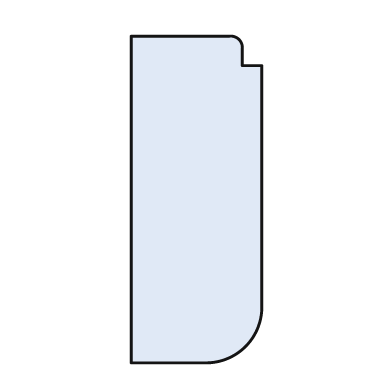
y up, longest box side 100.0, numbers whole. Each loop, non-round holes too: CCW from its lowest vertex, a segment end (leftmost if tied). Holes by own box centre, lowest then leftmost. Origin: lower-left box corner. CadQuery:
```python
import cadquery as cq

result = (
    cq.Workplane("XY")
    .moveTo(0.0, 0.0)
    .lineTo(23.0, 0.0)
    .threePointArc((35.0, 5.0), (40.0, 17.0))
    .lineTo(40.0, 91.0)
    .lineTo(34.0, 91.0)
    .lineTo(34.0, 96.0)
    .threePointArc((33.0, 99.0), (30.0, 100.0))
    .lineTo(0.0, 100.0)
    .close()
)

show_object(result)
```